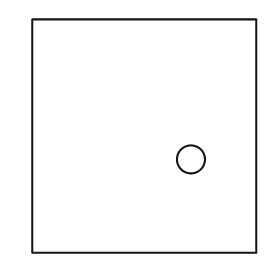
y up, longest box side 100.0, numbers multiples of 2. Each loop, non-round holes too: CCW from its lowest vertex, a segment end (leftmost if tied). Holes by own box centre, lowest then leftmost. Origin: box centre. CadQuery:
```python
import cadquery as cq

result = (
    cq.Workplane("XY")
    .moveTo(-48.0, -50.0)
    .lineTo(48.0, -50.0)
    .lineTo(48.0, 50.0)
    .lineTo(-48.0, 50.0)
    .close()
    .moveTo(20.0, -10.0)
    .circle(6.0)
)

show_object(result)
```